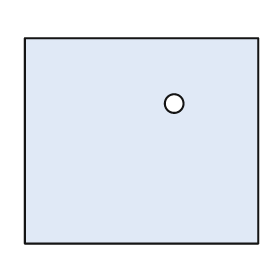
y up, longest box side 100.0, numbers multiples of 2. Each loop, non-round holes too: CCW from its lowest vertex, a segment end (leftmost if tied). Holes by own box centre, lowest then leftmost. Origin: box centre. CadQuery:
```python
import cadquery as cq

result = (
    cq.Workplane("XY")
    .moveTo(-50.0, -44.0)
    .lineTo(50.0, -44.0)
    .lineTo(50.0, 44.0)
    .lineTo(-50.0, 44.0)
    .close()
    .moveTo(14.0, 16.0)
    .circle(4.0)
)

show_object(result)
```